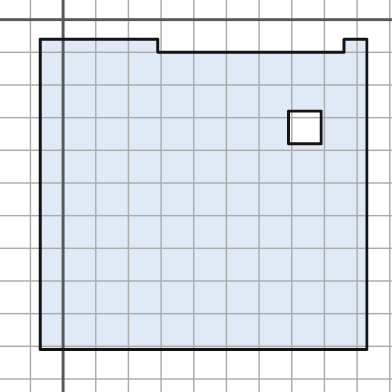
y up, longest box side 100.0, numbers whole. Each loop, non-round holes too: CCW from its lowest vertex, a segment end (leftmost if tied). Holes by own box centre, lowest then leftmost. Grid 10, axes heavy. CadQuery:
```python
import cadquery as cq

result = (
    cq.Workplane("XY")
    .moveTo(-7.0, -101.0)
    .lineTo(93.0, -101.0)
    .lineTo(93.0, -6.0)
    .lineTo(86.0, -6.0)
    .lineTo(86.0, -10.0)
    .lineTo(29.0, -10.0)
    .lineTo(29.0, -6.0)
    .lineTo(-7.0, -6.0)
    .close()
    .moveTo(69.0, -38.0)
    .lineTo(79.0, -38.0)
    .lineTo(79.0, -28.0)
    .lineTo(69.0, -28.0)
    .close()
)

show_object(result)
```